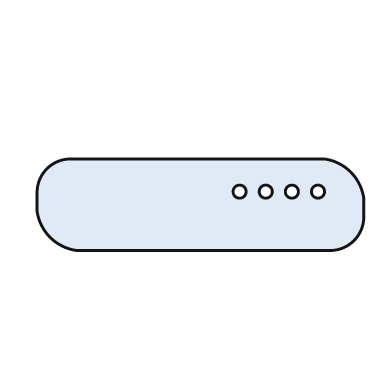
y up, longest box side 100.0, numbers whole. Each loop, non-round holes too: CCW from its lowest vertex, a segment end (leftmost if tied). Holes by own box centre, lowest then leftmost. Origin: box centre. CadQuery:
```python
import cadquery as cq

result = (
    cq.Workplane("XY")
    .moveTo(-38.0, -14.0)
    .lineTo(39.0, -14.0)
    .threePointArc((47.0, -11.0), (50.0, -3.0))
    .lineTo(50.0, 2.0)
    .threePointArc((46.0, 10.0), (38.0, 14.0))
    .lineTo(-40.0, 14.0)
    .threePointArc((-47.0, 11.0), (-50.0, 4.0))
    .lineTo(-50.0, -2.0)
    .threePointArc((-46.0, -10.0), (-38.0, -14.0))
    .close()
    .moveTo(12.0, 4.0)
    .circle(2.0)
    .moveTo(20.0, 4.0)
    .circle(2.0)
    .moveTo(28.0, 4.0)
    .circle(2.0)
    .moveTo(36.0, 4.0)
    .circle(2.0)
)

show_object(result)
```